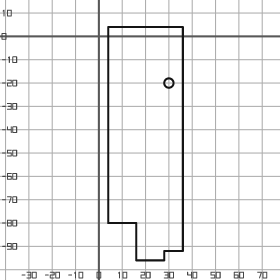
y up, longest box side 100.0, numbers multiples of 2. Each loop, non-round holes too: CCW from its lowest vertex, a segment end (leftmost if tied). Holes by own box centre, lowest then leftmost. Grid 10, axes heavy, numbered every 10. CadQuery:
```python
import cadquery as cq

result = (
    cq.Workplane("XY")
    .moveTo(16.0, -96.0)
    .lineTo(28.0, -96.0)
    .lineTo(28.0, -92.0)
    .lineTo(36.0, -92.0)
    .lineTo(36.0, 4.0)
    .lineTo(4.0, 4.0)
    .lineTo(4.0, -80.0)
    .lineTo(16.0, -80.0)
    .close()
    .moveTo(30.0, -20.0)
    .circle(2.0)
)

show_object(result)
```